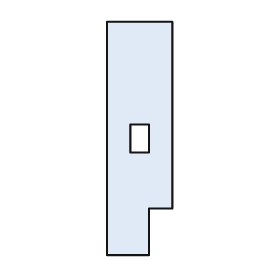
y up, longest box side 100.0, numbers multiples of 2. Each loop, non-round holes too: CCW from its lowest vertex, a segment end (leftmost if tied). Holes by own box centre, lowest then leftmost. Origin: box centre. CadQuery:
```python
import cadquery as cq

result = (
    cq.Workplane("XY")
    .moveTo(-14.0, -50.0)
    .lineTo(4.0, -50.0)
    .lineTo(4.0, -30.0)
    .lineTo(14.0, -30.0)
    .lineTo(14.0, 50.0)
    .lineTo(-14.0, 50.0)
    .close()
    .moveTo(-4.0, -6.0)
    .lineTo(4.0, -6.0)
    .lineTo(4.0, 6.0)
    .lineTo(-4.0, 6.0)
    .close()
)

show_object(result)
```